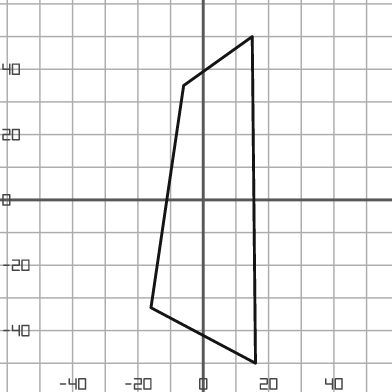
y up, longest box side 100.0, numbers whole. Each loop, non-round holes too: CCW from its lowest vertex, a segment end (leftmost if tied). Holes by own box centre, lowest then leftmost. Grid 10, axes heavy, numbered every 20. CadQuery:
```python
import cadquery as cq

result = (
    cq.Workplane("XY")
    .moveTo(16.0, -50.0)
    .lineTo(15.0, 50.0)
    .lineTo(-6.0, 35.0)
    .lineTo(-16.0, -33.0)
    .close()
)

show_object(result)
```